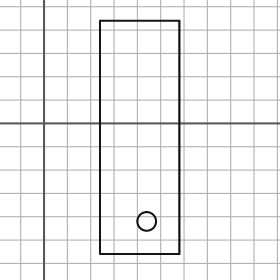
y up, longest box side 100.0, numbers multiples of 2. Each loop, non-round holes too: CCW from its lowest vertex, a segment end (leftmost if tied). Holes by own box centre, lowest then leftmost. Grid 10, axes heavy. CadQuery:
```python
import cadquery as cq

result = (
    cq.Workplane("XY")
    .moveTo(24.0, -56.0)
    .lineTo(58.0, -56.0)
    .lineTo(58.0, 44.0)
    .lineTo(24.0, 44.0)
    .close()
    .moveTo(44.0, -42.0)
    .circle(4.0)
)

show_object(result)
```